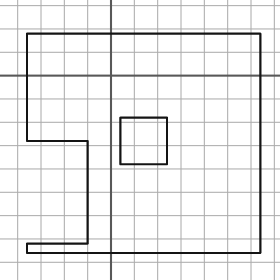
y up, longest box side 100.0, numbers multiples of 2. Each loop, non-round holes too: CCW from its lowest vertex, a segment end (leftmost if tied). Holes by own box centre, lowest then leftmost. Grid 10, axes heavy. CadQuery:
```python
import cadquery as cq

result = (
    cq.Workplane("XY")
    .moveTo(-36.0, -76.0)
    .lineTo(64.0, -76.0)
    .lineTo(64.0, 18.0)
    .lineTo(-36.0, 18.0)
    .lineTo(-36.0, -28.0)
    .lineTo(-10.0, -28.0)
    .lineTo(-10.0, -72.0)
    .lineTo(-36.0, -72.0)
    .close()
    .moveTo(4.0, -38.0)
    .lineTo(24.0, -38.0)
    .lineTo(24.0, -18.0)
    .lineTo(4.0, -18.0)
    .close()
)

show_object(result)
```